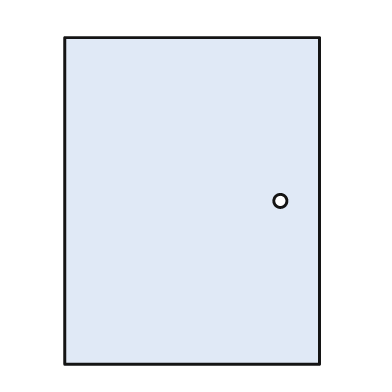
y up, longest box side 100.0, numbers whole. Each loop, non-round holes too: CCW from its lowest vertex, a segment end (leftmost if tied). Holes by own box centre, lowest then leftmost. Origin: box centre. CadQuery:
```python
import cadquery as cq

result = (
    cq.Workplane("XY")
    .moveTo(-39.0, -50.0)
    .lineTo(39.0, -50.0)
    .lineTo(39.0, 50.0)
    .lineTo(-39.0, 50.0)
    .close()
    .moveTo(27.0, 0.0)
    .circle(2.0)
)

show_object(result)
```